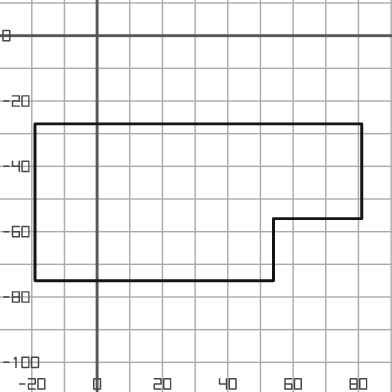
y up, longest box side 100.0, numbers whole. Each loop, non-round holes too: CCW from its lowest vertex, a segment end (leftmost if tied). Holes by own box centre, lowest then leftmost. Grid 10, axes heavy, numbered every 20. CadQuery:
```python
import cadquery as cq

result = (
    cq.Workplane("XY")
    .moveTo(-19.0, -75.0)
    .lineTo(54.0, -75.0)
    .lineTo(54.0, -56.0)
    .lineTo(81.0, -56.0)
    .lineTo(81.0, -27.0)
    .lineTo(-19.0, -27.0)
    .close()
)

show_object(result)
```